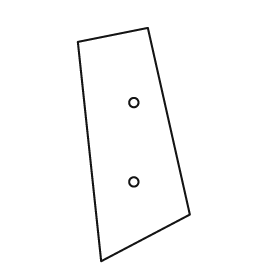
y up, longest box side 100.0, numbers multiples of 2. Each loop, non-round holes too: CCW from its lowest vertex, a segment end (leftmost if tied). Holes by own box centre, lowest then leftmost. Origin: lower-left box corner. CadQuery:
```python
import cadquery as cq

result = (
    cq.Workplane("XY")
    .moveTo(10.0, 0.0)
    .lineTo(48.0, 20.0)
    .lineTo(30.0, 100.0)
    .lineTo(0.0, 94.0)
    .close()
    .moveTo(24.0, 34.0)
    .circle(2.0)
    .moveTo(24.0, 68.0)
    .circle(2.0)
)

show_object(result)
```